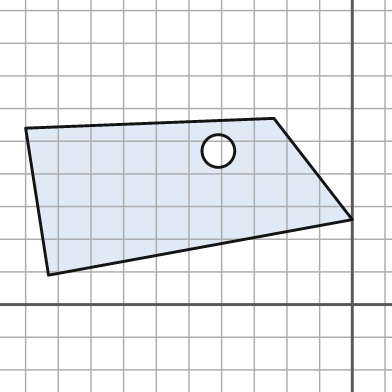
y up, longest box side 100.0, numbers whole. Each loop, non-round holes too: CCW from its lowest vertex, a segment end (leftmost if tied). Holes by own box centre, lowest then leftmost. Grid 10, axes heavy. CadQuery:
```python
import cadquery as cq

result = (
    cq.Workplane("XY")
    .moveTo(-93.0, 9.0)
    .lineTo(0.0, 26.0)
    .lineTo(-24.0, 57.0)
    .lineTo(-100.0, 54.0)
    .close()
    .moveTo(-41.0, 47.0)
    .circle(5.0)
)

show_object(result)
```